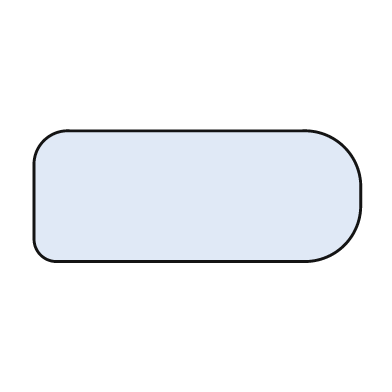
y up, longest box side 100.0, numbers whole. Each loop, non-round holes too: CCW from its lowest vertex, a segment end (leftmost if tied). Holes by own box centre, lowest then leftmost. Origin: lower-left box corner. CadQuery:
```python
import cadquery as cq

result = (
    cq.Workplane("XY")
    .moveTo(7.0, 0.0)
    .lineTo(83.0, 0.0)
    .threePointArc((95.0, 5.0), (100.0, 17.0))
    .lineTo(100.0, 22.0)
    .threePointArc((95.0, 35.0), (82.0, 40.0))
    .lineTo(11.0, 40.0)
    .threePointArc((3.0, 37.0), (0.0, 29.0))
    .lineTo(0.0, 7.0)
    .threePointArc((2.0, 2.0), (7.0, 0.0))
    .close()
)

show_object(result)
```